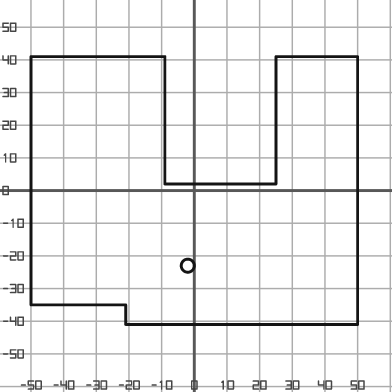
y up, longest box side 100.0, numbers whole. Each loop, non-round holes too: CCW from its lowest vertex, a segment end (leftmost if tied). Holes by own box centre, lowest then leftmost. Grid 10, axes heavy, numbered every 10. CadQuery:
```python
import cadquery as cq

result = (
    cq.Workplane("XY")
    .moveTo(-21.0, -41.0)
    .lineTo(50.0, -41.0)
    .lineTo(50.0, 41.0)
    .lineTo(25.0, 41.0)
    .lineTo(25.0, 2.0)
    .lineTo(-9.0, 2.0)
    .lineTo(-9.0, 41.0)
    .lineTo(-50.0, 41.0)
    .lineTo(-50.0, -35.0)
    .lineTo(-21.0, -35.0)
    .close()
    .moveTo(-2.0, -23.0)
    .circle(2.0)
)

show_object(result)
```